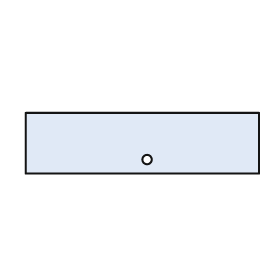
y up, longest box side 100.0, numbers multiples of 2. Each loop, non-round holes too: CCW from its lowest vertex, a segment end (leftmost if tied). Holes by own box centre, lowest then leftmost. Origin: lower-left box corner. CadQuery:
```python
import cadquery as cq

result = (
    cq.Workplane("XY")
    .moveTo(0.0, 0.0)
    .lineTo(100.0, 0.0)
    .lineTo(100.0, 26.0)
    .lineTo(0.0, 26.0)
    .close()
    .moveTo(52.0, 6.0)
    .circle(2.0)
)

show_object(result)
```